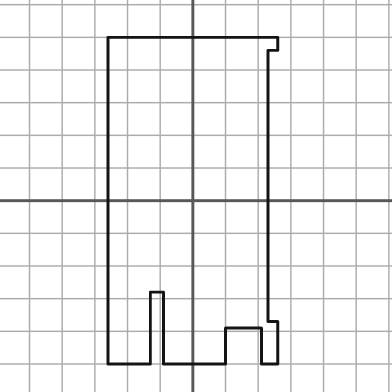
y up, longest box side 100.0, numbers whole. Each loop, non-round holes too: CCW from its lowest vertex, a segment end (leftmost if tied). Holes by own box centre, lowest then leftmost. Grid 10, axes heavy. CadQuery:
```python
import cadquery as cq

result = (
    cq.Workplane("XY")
    .moveTo(-26.0, -50.0)
    .lineTo(-13.0, -50.0)
    .lineTo(-13.0, -28.0)
    .lineTo(-9.0, -28.0)
    .lineTo(-9.0, -50.0)
    .lineTo(10.0, -50.0)
    .lineTo(10.0, -39.0)
    .lineTo(21.0, -39.0)
    .lineTo(21.0, -50.0)
    .lineTo(26.0, -50.0)
    .lineTo(26.0, -37.0)
    .lineTo(23.0, -37.0)
    .lineTo(23.0, 46.0)
    .lineTo(26.0, 46.0)
    .lineTo(26.0, 50.0)
    .lineTo(-26.0, 50.0)
    .close()
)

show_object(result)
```